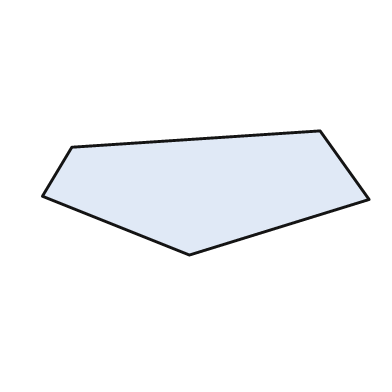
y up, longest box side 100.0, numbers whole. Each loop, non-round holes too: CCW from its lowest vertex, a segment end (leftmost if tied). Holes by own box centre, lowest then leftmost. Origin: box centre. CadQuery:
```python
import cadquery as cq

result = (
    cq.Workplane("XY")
    .moveTo(-5.0, -19.0)
    .lineTo(50.0, -2.0)
    .lineTo(35.0, 19.0)
    .lineTo(-41.0, 14.0)
    .lineTo(-50.0, -1.0)
    .close()
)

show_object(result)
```